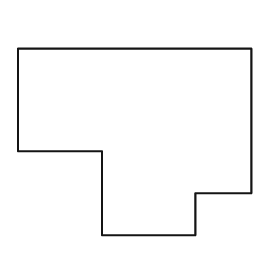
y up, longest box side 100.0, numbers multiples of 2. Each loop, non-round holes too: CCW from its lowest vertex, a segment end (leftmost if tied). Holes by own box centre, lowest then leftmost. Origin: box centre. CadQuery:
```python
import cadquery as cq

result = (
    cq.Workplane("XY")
    .moveTo(-14.0, -40.0)
    .lineTo(26.0, -40.0)
    .lineTo(26.0, -22.0)
    .lineTo(50.0, -22.0)
    .lineTo(50.0, 40.0)
    .lineTo(-50.0, 40.0)
    .lineTo(-50.0, -4.0)
    .lineTo(-14.0, -4.0)
    .close()
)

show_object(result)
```